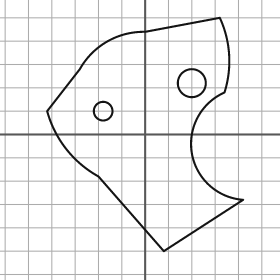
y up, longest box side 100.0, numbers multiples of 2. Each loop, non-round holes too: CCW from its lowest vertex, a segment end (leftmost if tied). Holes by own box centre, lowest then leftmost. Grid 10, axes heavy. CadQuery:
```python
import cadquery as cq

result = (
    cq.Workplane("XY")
    .moveTo(8.0, -50.0)
    .lineTo(42.0, -28.0)
    .threePointArc((20.0, -8.0), (34.0, 18.0))
    .threePointArc((36.0, 34.0), (32.0, 50.0))
    .lineTo(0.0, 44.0)
    .threePointArc((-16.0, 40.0), (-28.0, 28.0))
    .lineTo(-42.0, 10.0)
    .threePointArc((-34.0, -6.0), (-20.0, -18.0))
    .close()
    .moveTo(-18.0, 10.0)
    .circle(4.0)
    .moveTo(20.0, 22.0)
    .circle(6.0)
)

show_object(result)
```